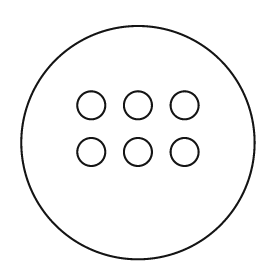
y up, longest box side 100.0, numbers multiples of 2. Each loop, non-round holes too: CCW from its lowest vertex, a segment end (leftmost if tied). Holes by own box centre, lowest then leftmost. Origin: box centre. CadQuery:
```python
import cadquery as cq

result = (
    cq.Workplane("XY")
    .moveTo(0.0, 0.0)
    .circle(50.0)
    .moveTo(-20.0, -4.0)
    .circle(6.0)
    .moveTo(0.0, -4.0)
    .circle(6.0)
    .moveTo(20.0, -4.0)
    .circle(6.0)
    .moveTo(-20.0, 16.0)
    .circle(6.0)
    .moveTo(0.0, 16.0)
    .circle(6.0)
    .moveTo(20.0, 16.0)
    .circle(6.0)
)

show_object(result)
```